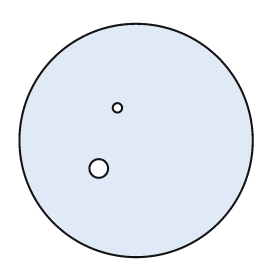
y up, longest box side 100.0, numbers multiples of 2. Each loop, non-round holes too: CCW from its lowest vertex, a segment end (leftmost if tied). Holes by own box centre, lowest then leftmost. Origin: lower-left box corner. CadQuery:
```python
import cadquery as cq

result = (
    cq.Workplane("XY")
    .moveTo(50.0, 50.0)
    .circle(50.0)
    .moveTo(34.0, 38.0)
    .circle(4.0)
    .moveTo(42.0, 64.0)
    .circle(2.0)
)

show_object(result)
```